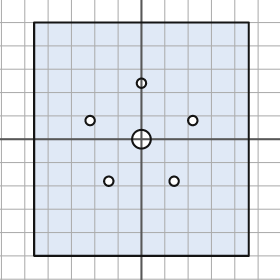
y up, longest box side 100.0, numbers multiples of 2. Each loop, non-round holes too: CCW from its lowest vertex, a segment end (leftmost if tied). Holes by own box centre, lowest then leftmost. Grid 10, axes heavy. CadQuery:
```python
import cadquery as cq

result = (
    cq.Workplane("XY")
    .moveTo(-46.0, -50.0)
    .lineTo(46.0, -50.0)
    .lineTo(46.0, 50.0)
    .lineTo(-46.0, 50.0)
    .close()
    .moveTo(-14.0, -18.0)
    .circle(2.0)
    .moveTo(14.0, -18.0)
    .circle(2.0)
    .moveTo(0.0, 0.0)
    .circle(4.0)
    .moveTo(-22.0, 8.0)
    .circle(2.0)
    .moveTo(22.0, 8.0)
    .circle(2.0)
    .moveTo(0.0, 24.0)
    .circle(2.0)
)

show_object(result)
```